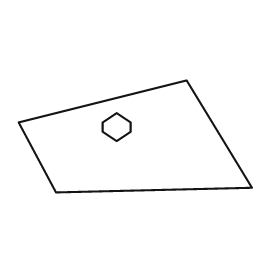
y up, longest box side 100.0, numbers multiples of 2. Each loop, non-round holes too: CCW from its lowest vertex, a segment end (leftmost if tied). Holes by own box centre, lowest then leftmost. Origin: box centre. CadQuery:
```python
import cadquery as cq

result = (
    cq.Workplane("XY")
    .moveTo(-34.0, -24.0)
    .lineTo(50.0, -22.0)
    .lineTo(22.0, 24.0)
    .lineTo(-50.0, 6.0)
    .close()
    .moveTo(-8.0, -2.0)
    .lineTo(-2.0, 2.0)
    .lineTo(-2.0, 6.0)
    .lineTo(-8.0, 10.0)
    .lineTo(-14.0, 6.0)
    .lineTo(-14.0, 2.0)
    .close()
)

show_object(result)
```